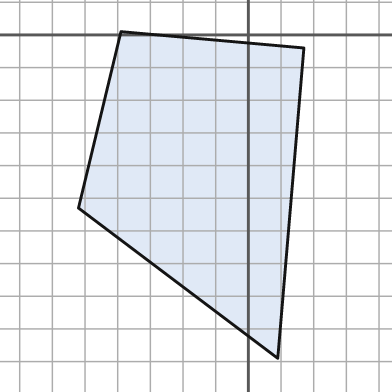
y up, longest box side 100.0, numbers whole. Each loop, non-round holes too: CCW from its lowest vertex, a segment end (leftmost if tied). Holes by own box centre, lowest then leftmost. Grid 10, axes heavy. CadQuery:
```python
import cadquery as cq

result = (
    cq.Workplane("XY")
    .moveTo(9.0, -99.0)
    .lineTo(17.0, -4.0)
    .lineTo(-39.0, 1.0)
    .lineTo(-52.0, -53.0)
    .close()
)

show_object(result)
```